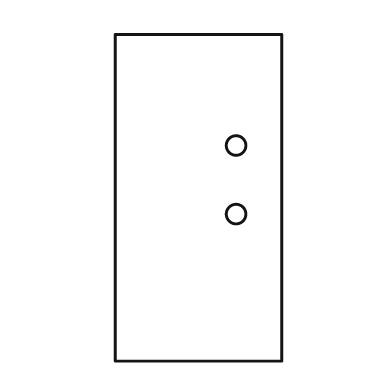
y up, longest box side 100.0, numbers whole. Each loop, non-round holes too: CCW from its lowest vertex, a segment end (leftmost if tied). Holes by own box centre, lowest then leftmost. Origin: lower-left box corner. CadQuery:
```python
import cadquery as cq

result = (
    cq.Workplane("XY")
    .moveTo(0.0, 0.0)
    .lineTo(51.0, 0.0)
    .lineTo(51.0, 100.0)
    .lineTo(0.0, 100.0)
    .close()
    .moveTo(37.0, 45.0)
    .circle(3.0)
    .moveTo(37.0, 66.0)
    .circle(3.0)
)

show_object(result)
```